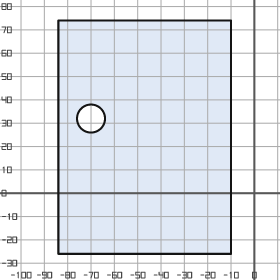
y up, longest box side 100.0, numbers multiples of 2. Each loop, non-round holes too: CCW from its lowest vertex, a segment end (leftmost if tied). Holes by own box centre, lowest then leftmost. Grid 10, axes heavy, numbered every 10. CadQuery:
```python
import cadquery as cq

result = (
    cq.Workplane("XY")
    .moveTo(-84.0, -26.0)
    .lineTo(-10.0, -26.0)
    .lineTo(-10.0, 74.0)
    .lineTo(-84.0, 74.0)
    .close()
    .moveTo(-70.0, 32.0)
    .circle(6.0)
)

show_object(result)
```